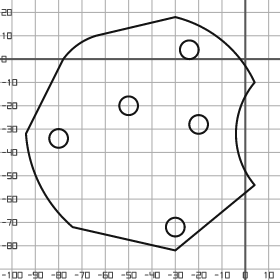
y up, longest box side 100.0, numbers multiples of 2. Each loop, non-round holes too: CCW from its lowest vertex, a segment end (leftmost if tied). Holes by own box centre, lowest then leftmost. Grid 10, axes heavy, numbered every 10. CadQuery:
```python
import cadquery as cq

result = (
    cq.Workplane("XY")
    .moveTo(-30.0, -82.0)
    .lineTo(4.0, -54.0)
    .threePointArc((-4.0, -32.0), (4.0, -10.0))
    .threePointArc((-10.0, 8.0), (-30.0, 18.0))
    .lineTo(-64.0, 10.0)
    .threePointArc((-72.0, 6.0), (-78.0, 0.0))
    .lineTo(-94.0, -32.0)
    .threePointArc((-88.0, -54.0), (-74.0, -72.0))
    .close()
    .moveTo(-30.0, -72.0)
    .circle(4.0)
    .moveTo(-80.0, -34.0)
    .circle(4.0)
    .moveTo(-20.0, -28.0)
    .circle(4.0)
    .moveTo(-50.0, -20.0)
    .circle(4.0)
    .moveTo(-24.0, 4.0)
    .circle(4.0)
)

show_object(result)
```